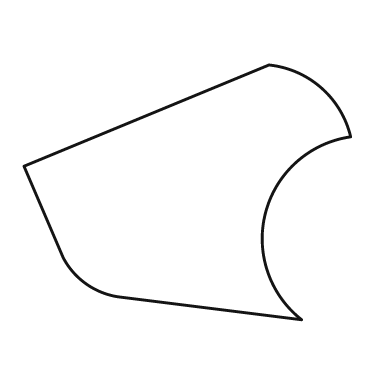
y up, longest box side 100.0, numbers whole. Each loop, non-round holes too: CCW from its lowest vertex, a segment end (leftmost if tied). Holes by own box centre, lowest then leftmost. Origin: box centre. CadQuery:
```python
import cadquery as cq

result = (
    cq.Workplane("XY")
    .moveTo(35.0, -39.0)
    .threePointArc((24.0, -6.0), (50.0, 17.0))
    .threePointArc((41.0, 32.0), (25.0, 39.0))
    .lineTo(-50.0, 8.0)
    .lineTo(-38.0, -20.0)
    .threePointArc((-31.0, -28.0), (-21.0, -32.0))
    .close()
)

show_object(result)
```